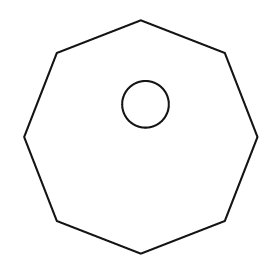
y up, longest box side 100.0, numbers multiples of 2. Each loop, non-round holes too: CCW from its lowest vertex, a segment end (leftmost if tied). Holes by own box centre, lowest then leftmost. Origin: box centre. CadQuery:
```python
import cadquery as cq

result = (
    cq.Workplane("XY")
    .moveTo(0.0, -50.0)
    .lineTo(36.0, -36.0)
    .lineTo(50.0, 0.0)
    .lineTo(36.0, 36.0)
    .lineTo(0.0, 50.0)
    .lineTo(-36.0, 36.0)
    .lineTo(-50.0, 0.0)
    .lineTo(-36.0, -36.0)
    .close()
    .moveTo(2.0, 14.0)
    .circle(10.0)
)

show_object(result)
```